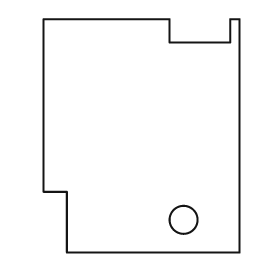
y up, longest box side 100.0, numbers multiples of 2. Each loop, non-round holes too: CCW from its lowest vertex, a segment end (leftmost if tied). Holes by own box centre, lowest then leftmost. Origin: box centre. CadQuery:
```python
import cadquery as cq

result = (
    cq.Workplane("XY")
    .moveTo(-32.0, -50.0)
    .lineTo(42.0, -50.0)
    .lineTo(42.0, 50.0)
    .lineTo(38.0, 50.0)
    .lineTo(38.0, 40.0)
    .lineTo(12.0, 40.0)
    .lineTo(12.0, 50.0)
    .lineTo(-42.0, 50.0)
    .lineTo(-42.0, -24.0)
    .lineTo(-32.0, -24.0)
    .close()
    .moveTo(18.0, -36.0)
    .circle(6.0)
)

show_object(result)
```